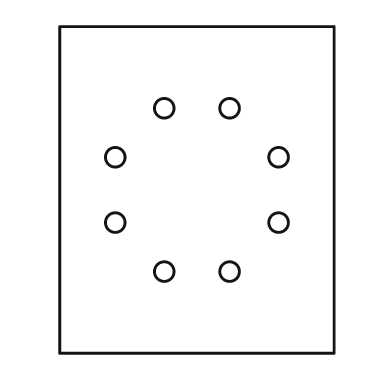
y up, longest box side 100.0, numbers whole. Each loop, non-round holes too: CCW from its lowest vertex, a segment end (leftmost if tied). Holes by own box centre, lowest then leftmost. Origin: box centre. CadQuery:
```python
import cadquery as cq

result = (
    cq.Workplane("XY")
    .moveTo(-42.0, -50.0)
    .lineTo(42.0, -50.0)
    .lineTo(42.0, 50.0)
    .lineTo(-42.0, 50.0)
    .close()
    .moveTo(-10.0, -25.0)
    .circle(3.0)
    .moveTo(10.0, -25.0)
    .circle(3.0)
    .moveTo(-25.0, -10.0)
    .circle(3.0)
    .moveTo(25.0, -10.0)
    .circle(3.0)
    .moveTo(-25.0, 10.0)
    .circle(3.0)
    .moveTo(25.0, 10.0)
    .circle(3.0)
    .moveTo(-10.0, 25.0)
    .circle(3.0)
    .moveTo(10.0, 25.0)
    .circle(3.0)
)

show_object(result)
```